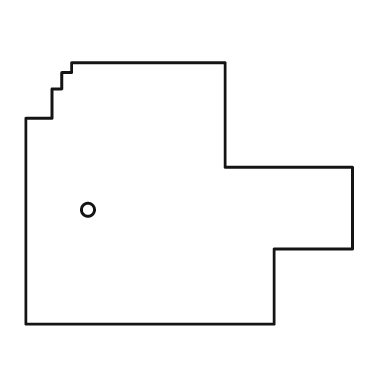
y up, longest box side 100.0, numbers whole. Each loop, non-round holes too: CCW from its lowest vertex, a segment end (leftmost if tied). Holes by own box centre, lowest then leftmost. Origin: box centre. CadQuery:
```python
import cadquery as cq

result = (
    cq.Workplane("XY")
    .moveTo(-50.0, -40.0)
    .lineTo(26.0, -40.0)
    .lineTo(26.0, -17.0)
    .lineTo(50.0, -17.0)
    .lineTo(50.0, 8.0)
    .lineTo(11.0, 8.0)
    .lineTo(11.0, 40.0)
    .lineTo(-36.0, 40.0)
    .lineTo(-36.0, 37.0)
    .lineTo(-39.0, 37.0)
    .lineTo(-39.0, 32.0)
    .lineTo(-42.0, 32.0)
    .lineTo(-42.0, 23.0)
    .lineTo(-50.0, 23.0)
    .close()
    .moveTo(-31.0, -5.0)
    .circle(2.0)
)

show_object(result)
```